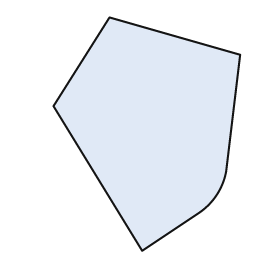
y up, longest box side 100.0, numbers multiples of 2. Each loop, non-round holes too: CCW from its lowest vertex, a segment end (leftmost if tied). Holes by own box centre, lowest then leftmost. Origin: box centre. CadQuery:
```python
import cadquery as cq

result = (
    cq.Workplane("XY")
    .moveTo(-2.0, -50.0)
    .lineTo(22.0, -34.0)
    .threePointArc((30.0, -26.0), (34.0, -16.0))
    .lineTo(40.0, 34.0)
    .lineTo(-16.0, 50.0)
    .lineTo(-40.0, 12.0)
    .close()
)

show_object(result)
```